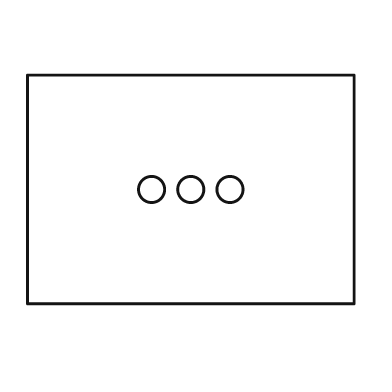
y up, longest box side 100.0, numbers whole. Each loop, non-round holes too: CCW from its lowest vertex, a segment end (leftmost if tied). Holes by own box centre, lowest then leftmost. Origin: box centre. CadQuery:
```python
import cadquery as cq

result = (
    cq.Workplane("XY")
    .moveTo(-50.0, -35.0)
    .lineTo(50.0, -35.0)
    .lineTo(50.0, 35.0)
    .lineTo(-50.0, 35.0)
    .close()
    .moveTo(-12.0, 0.0)
    .circle(4.0)
    .moveTo(0.0, 0.0)
    .circle(4.0)
    .moveTo(12.0, 0.0)
    .circle(4.0)
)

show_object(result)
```